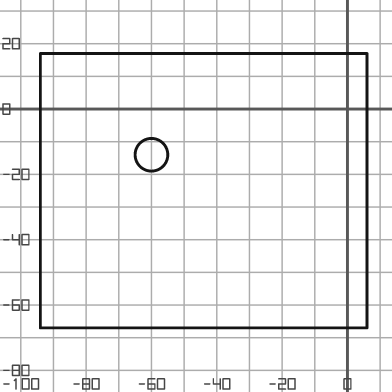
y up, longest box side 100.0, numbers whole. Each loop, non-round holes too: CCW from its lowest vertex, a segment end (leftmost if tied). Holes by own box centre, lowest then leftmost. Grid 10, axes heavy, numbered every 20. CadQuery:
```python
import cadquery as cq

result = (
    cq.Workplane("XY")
    .moveTo(-94.0, -67.0)
    .lineTo(6.0, -67.0)
    .lineTo(6.0, 17.0)
    .lineTo(-94.0, 17.0)
    .close()
    .moveTo(-60.0, -14.0)
    .circle(5.0)
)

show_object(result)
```